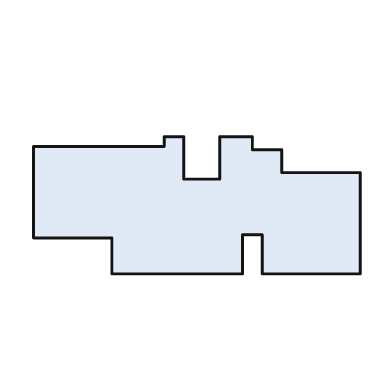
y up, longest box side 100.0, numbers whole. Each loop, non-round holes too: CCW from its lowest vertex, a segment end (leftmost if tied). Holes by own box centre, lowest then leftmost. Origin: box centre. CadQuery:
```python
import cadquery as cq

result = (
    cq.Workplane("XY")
    .moveTo(-26.0, -21.0)
    .lineTo(14.0, -21.0)
    .lineTo(14.0, -9.0)
    .lineTo(20.0, -9.0)
    .lineTo(20.0, -21.0)
    .lineTo(50.0, -21.0)
    .lineTo(50.0, 10.0)
    .lineTo(26.0, 10.0)
    .lineTo(26.0, 17.0)
    .lineTo(17.0, 17.0)
    .lineTo(17.0, 21.0)
    .lineTo(7.0, 21.0)
    .lineTo(7.0, 8.0)
    .lineTo(-4.0, 8.0)
    .lineTo(-4.0, 21.0)
    .lineTo(-10.0, 21.0)
    .lineTo(-10.0, 18.0)
    .lineTo(-50.0, 18.0)
    .lineTo(-50.0, -10.0)
    .lineTo(-26.0, -10.0)
    .close()
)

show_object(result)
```